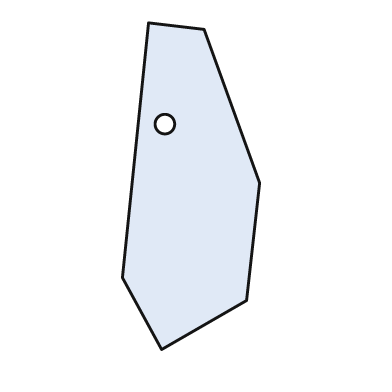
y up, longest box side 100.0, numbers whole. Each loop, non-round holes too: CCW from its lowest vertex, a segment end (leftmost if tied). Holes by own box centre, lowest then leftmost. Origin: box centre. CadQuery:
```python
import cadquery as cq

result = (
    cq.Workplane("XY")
    .moveTo(-9.0, -50.0)
    .lineTo(17.0, -35.0)
    .lineTo(21.0, 1.0)
    .lineTo(4.0, 48.0)
    .lineTo(-13.0, 50.0)
    .lineTo(-21.0, -28.0)
    .close()
    .moveTo(-8.0, 19.0)
    .circle(3.0)
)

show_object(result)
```